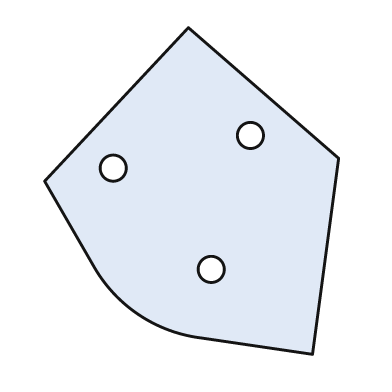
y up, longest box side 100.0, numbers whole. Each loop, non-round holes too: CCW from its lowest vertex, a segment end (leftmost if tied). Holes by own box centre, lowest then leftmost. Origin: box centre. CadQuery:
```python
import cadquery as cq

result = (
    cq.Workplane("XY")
    .moveTo(37.0, -50.0)
    .lineTo(45.0, 10.0)
    .lineTo(-1.0, 50.0)
    .lineTo(-45.0, 3.0)
    .lineTo(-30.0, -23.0)
    .threePointArc((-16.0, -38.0), (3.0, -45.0))
    .close()
    .moveTo(6.0, -24.0)
    .circle(4.0)
    .moveTo(-24.0, 7.0)
    .circle(4.0)
    .moveTo(18.0, 17.0)
    .circle(4.0)
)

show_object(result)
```